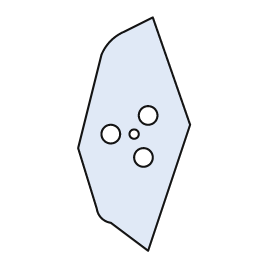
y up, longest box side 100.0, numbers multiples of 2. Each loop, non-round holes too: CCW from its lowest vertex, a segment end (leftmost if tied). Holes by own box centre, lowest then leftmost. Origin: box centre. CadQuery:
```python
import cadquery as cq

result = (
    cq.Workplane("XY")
    .moveTo(6.0, -50.0)
    .lineTo(24.0, 4.0)
    .lineTo(8.0, 50.0)
    .lineTo(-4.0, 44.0)
    .threePointArc((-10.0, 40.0), (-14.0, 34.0))
    .lineTo(-24.0, -6.0)
    .lineTo(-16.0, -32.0)
    .threePointArc((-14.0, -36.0), (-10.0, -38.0))
    .close()
    .moveTo(4.0, -10.0)
    .circle(4.0)
    .moveTo(-10.0, 0.0)
    .circle(4.0)
    .moveTo(0.0, 0.0)
    .circle(2.0)
    .moveTo(6.0, 8.0)
    .circle(4.0)
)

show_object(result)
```